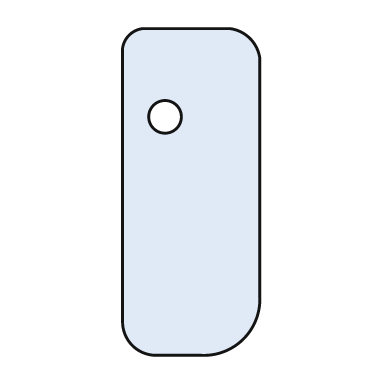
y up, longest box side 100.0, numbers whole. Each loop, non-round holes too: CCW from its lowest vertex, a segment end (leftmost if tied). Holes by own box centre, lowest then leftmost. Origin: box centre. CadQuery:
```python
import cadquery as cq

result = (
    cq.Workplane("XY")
    .moveTo(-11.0, -50.0)
    .lineTo(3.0, -50.0)
    .threePointArc((16.0, -45.0), (21.0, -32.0))
    .lineTo(21.0, 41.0)
    .threePointArc((18.0, 47.0), (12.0, 50.0))
    .lineTo(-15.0, 50.0)
    .threePointArc((-19.0, 48.0), (-21.0, 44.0))
    .lineTo(-21.0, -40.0)
    .threePointArc((-18.0, -47.0), (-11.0, -50.0))
    .close()
    .moveTo(-8.0, 23.0)
    .circle(5.0)
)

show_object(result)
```